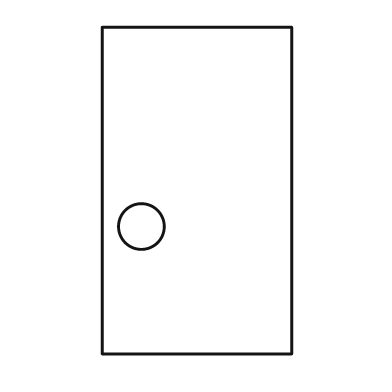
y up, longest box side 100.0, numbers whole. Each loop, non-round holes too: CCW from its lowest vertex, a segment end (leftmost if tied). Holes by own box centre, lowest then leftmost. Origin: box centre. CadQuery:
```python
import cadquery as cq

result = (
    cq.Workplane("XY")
    .moveTo(-29.0, -50.0)
    .lineTo(29.0, -50.0)
    .lineTo(29.0, 50.0)
    .lineTo(-29.0, 50.0)
    .close()
    .moveTo(-17.0, -11.0)
    .circle(7.0)
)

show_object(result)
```